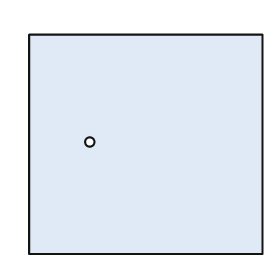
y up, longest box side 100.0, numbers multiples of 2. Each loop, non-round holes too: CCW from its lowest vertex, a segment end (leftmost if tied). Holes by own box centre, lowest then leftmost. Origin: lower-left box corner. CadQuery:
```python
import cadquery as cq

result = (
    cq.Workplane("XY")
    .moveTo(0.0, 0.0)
    .lineTo(100.0, 0.0)
    .lineTo(100.0, 94.0)
    .lineTo(0.0, 94.0)
    .close()
    .moveTo(26.0, 48.0)
    .circle(2.0)
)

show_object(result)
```